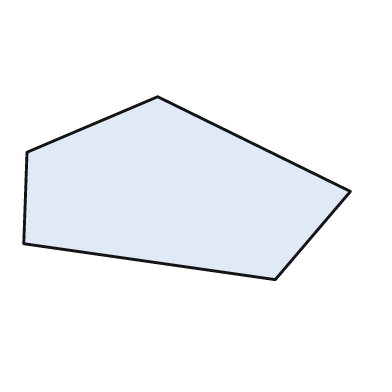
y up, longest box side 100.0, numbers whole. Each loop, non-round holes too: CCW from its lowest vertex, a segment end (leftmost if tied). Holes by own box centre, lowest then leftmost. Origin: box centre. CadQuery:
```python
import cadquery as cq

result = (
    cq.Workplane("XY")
    .moveTo(27.0, -28.0)
    .lineTo(50.0, -1.0)
    .lineTo(-9.0, 28.0)
    .lineTo(-49.0, 11.0)
    .lineTo(-50.0, -17.0)
    .close()
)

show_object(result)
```